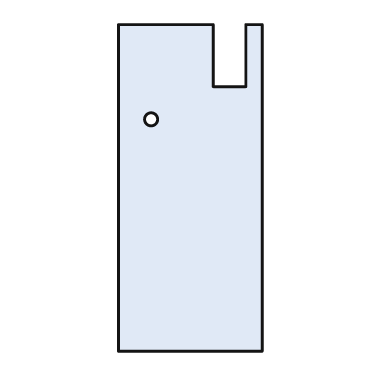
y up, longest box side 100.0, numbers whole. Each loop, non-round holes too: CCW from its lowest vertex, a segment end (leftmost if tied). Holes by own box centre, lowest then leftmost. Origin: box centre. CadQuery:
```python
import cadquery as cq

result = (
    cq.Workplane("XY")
    .moveTo(-22.0, -50.0)
    .lineTo(22.0, -50.0)
    .lineTo(22.0, 50.0)
    .lineTo(17.0, 50.0)
    .lineTo(17.0, 31.0)
    .lineTo(7.0, 31.0)
    .lineTo(7.0, 50.0)
    .lineTo(-22.0, 50.0)
    .close()
    .moveTo(-12.0, 21.0)
    .circle(2.0)
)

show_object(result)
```